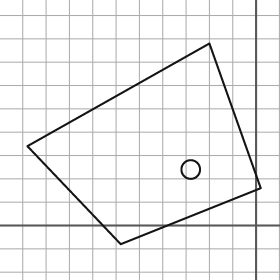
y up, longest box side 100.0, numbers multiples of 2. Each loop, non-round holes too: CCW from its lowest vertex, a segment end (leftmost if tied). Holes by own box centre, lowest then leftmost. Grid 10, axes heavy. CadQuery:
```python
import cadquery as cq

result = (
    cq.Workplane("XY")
    .moveTo(-58.0, -8.0)
    .lineTo(2.0, 16.0)
    .lineTo(-20.0, 78.0)
    .lineTo(-98.0, 34.0)
    .close()
    .moveTo(-28.0, 24.0)
    .circle(4.0)
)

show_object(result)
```